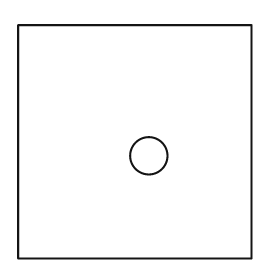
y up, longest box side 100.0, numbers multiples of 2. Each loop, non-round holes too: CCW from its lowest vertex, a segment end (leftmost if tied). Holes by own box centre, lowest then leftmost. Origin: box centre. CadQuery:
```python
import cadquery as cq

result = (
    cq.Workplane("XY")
    .moveTo(-50.0, -50.0)
    .lineTo(50.0, -50.0)
    .lineTo(50.0, 50.0)
    .lineTo(-50.0, 50.0)
    .close()
    .moveTo(6.0, -6.0)
    .circle(8.0)
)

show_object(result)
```